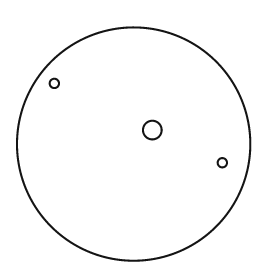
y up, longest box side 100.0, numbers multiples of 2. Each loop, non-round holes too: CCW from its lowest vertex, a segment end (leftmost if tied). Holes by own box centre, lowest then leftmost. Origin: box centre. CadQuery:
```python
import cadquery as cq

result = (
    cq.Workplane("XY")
    .moveTo(0.0, 0.0)
    .circle(50.0)
    .moveTo(38.0, -8.0)
    .circle(2.0)
    .moveTo(8.0, 6.0)
    .circle(4.0)
    .moveTo(-34.0, 26.0)
    .circle(2.0)
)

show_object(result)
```